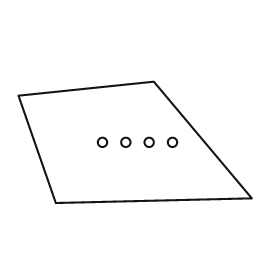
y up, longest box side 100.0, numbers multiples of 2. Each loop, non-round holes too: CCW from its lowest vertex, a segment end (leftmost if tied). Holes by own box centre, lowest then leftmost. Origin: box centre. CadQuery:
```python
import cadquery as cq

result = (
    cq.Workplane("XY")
    .moveTo(-34.0, -26.0)
    .lineTo(50.0, -24.0)
    .lineTo(8.0, 26.0)
    .lineTo(-50.0, 20.0)
    .close()
    .moveTo(-14.0, 0.0)
    .circle(2.0)
    .moveTo(-4.0, 0.0)
    .circle(2.0)
    .moveTo(6.0, 0.0)
    .circle(2.0)
    .moveTo(16.0, 0.0)
    .circle(2.0)
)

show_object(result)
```